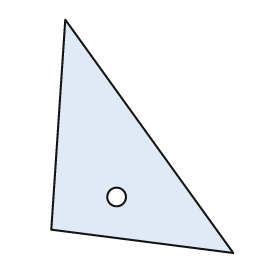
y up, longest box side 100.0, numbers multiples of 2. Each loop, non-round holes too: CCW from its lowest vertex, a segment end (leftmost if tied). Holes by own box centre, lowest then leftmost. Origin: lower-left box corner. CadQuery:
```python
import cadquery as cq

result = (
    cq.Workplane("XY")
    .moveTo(78.0, 0.0)
    .lineTo(6.0, 100.0)
    .lineTo(0.0, 10.0)
    .close()
    .moveTo(28.0, 24.0)
    .circle(4.0)
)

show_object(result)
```